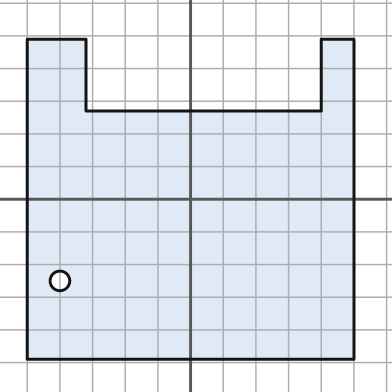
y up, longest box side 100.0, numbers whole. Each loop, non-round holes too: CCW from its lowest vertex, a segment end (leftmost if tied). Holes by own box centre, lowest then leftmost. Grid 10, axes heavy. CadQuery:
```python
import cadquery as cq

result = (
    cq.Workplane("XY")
    .moveTo(-50.0, -49.0)
    .lineTo(50.0, -49.0)
    .lineTo(50.0, 49.0)
    .lineTo(40.0, 49.0)
    .lineTo(40.0, 27.0)
    .lineTo(-32.0, 27.0)
    .lineTo(-32.0, 49.0)
    .lineTo(-50.0, 49.0)
    .close()
    .moveTo(-40.0, -25.0)
    .circle(3.0)
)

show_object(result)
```